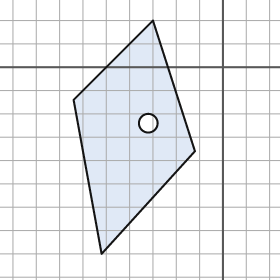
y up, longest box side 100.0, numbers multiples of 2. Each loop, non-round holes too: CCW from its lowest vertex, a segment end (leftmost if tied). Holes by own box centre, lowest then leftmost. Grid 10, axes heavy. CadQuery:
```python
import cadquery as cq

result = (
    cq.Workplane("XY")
    .moveTo(-52.0, -80.0)
    .lineTo(-12.0, -36.0)
    .lineTo(-30.0, 20.0)
    .lineTo(-64.0, -14.0)
    .close()
    .moveTo(-32.0, -24.0)
    .circle(4.0)
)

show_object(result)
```